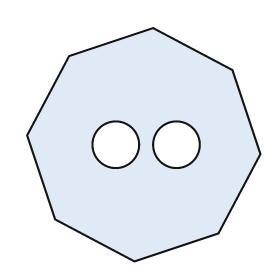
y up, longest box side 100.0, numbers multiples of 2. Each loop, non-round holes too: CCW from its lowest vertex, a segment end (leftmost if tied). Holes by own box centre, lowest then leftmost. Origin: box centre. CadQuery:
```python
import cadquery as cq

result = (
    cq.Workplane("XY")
    .moveTo(-4.0, -50.0)
    .lineTo(32.0, -38.0)
    .lineTo(50.0, -4.0)
    .lineTo(38.0, 32.0)
    .lineTo(4.0, 50.0)
    .lineTo(-32.0, 38.0)
    .lineTo(-50.0, 4.0)
    .lineTo(-38.0, -32.0)
    .close()
    .moveTo(-12.0, 0.0)
    .circle(10.0)
    .moveTo(14.0, 0.0)
    .circle(10.0)
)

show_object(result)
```